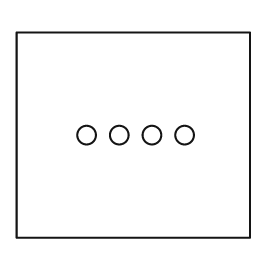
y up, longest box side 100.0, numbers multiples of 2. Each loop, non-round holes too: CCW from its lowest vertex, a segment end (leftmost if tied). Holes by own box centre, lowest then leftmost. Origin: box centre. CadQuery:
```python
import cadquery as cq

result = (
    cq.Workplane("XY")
    .moveTo(-50.0, -44.0)
    .lineTo(50.0, -44.0)
    .lineTo(50.0, 44.0)
    .lineTo(-50.0, 44.0)
    .close()
    .moveTo(-20.0, 0.0)
    .circle(4.0)
    .moveTo(-6.0, 0.0)
    .circle(4.0)
    .moveTo(8.0, 0.0)
    .circle(4.0)
    .moveTo(22.0, 0.0)
    .circle(4.0)
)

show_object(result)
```